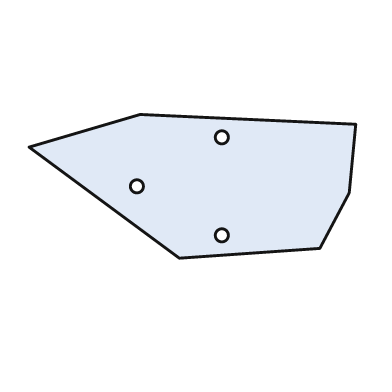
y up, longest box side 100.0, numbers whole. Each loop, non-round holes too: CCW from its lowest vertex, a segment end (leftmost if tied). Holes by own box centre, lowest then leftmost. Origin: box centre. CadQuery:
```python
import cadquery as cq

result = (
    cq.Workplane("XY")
    .moveTo(-4.0, -22.0)
    .lineTo(39.0, -19.0)
    .lineTo(48.0, -2.0)
    .lineTo(50.0, 19.0)
    .lineTo(-16.0, 22.0)
    .lineTo(-50.0, 12.0)
    .close()
    .moveTo(9.0, -15.0)
    .circle(2.0)
    .moveTo(-17.0, 0.0)
    .circle(2.0)
    .moveTo(9.0, 15.0)
    .circle(2.0)
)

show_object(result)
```